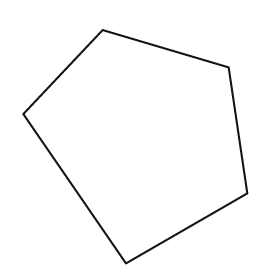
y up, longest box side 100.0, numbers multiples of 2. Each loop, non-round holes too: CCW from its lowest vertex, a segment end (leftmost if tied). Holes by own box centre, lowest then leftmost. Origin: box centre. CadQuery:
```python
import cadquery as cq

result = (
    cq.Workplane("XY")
    .moveTo(-4.0, -50.0)
    .lineTo(48.0, -20.0)
    .lineTo(40.0, 34.0)
    .lineTo(-14.0, 50.0)
    .lineTo(-48.0, 14.0)
    .close()
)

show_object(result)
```